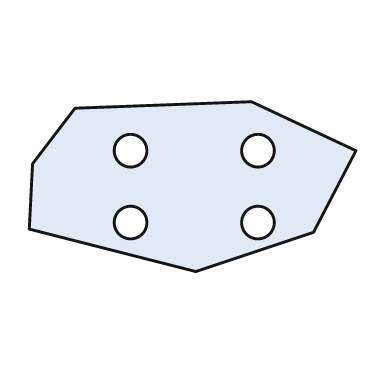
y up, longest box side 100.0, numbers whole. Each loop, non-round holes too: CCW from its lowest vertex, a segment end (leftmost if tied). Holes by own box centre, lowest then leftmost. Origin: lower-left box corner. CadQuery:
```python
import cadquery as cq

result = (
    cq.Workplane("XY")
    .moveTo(51.0, 0.0)
    .lineTo(87.0, 12.0)
    .lineTo(100.0, 37.0)
    .lineTo(68.0, 52.0)
    .lineTo(14.0, 50.0)
    .lineTo(1.0, 33.0)
    .lineTo(0.0, 13.0)
    .close()
    .moveTo(31.0, 15.0)
    .circle(5.0)
    .moveTo(70.0, 15.0)
    .circle(5.0)
    .moveTo(31.0, 37.0)
    .circle(5.0)
    .moveTo(70.0, 37.0)
    .circle(5.0)
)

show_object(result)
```